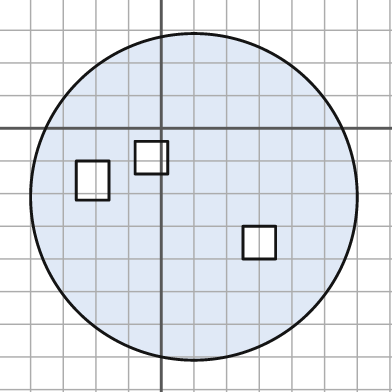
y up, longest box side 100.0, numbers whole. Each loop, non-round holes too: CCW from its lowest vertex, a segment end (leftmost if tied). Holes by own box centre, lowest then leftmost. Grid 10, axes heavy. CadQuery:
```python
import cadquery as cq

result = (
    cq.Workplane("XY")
    .moveTo(10.0, -21.0)
    .circle(50.0)
    .moveTo(25.0, -40.0)
    .lineTo(35.0, -40.0)
    .lineTo(35.0, -30.0)
    .lineTo(25.0, -30.0)
    .close()
    .moveTo(-26.0, -22.0)
    .lineTo(-16.0, -22.0)
    .lineTo(-16.0, -10.0)
    .lineTo(-26.0, -10.0)
    .close()
    .moveTo(-8.0, -14.0)
    .lineTo(2.0, -14.0)
    .lineTo(2.0, -4.0)
    .lineTo(-8.0, -4.0)
    .close()
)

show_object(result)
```